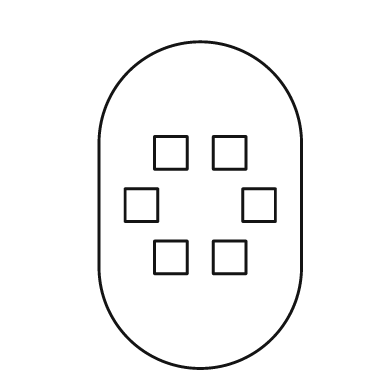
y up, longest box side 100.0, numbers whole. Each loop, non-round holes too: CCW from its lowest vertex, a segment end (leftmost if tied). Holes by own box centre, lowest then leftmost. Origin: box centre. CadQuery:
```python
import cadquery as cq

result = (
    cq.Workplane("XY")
    .moveTo(-31.0, -19.0)
    .threePointArc((0.0, -50.0), (31.0, -19.0))
    .lineTo(31.0, 19.0)
    .threePointArc((0.0, 50.0), (-31.0, 19.0))
    .close()
    .moveTo(-14.0, -21.0)
    .lineTo(-4.0, -21.0)
    .lineTo(-4.0, -11.0)
    .lineTo(-14.0, -11.0)
    .close()
    .moveTo(4.0, -21.0)
    .lineTo(14.0, -21.0)
    .lineTo(14.0, -11.0)
    .lineTo(4.0, -11.0)
    .close()
    .moveTo(-23.0, -5.0)
    .lineTo(-13.0, -5.0)
    .lineTo(-13.0, 5.0)
    .lineTo(-23.0, 5.0)
    .close()
    .moveTo(13.0, -5.0)
    .lineTo(23.0, -5.0)
    .lineTo(23.0, 5.0)
    .lineTo(13.0, 5.0)
    .close()
    .moveTo(-14.0, 11.0)
    .lineTo(-4.0, 11.0)
    .lineTo(-4.0, 21.0)
    .lineTo(-14.0, 21.0)
    .close()
    .moveTo(4.0, 11.0)
    .lineTo(14.0, 11.0)
    .lineTo(14.0, 21.0)
    .lineTo(4.0, 21.0)
    .close()
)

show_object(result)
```